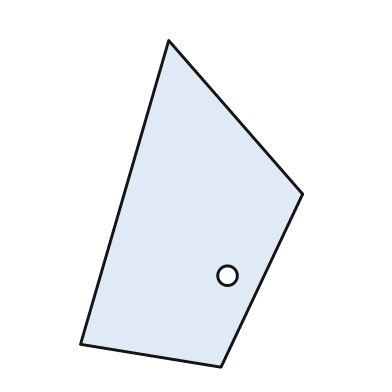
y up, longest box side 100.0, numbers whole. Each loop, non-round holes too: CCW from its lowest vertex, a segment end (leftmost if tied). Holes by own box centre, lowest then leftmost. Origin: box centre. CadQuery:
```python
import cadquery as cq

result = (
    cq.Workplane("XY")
    .moveTo(9.0, -50.0)
    .lineTo(34.0, 3.0)
    .lineTo(-7.0, 50.0)
    .lineTo(-34.0, -43.0)
    .close()
    .moveTo(11.0, -22.0)
    .circle(3.0)
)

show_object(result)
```